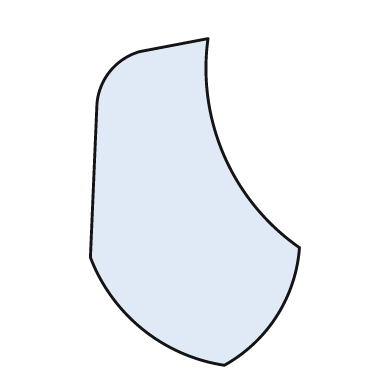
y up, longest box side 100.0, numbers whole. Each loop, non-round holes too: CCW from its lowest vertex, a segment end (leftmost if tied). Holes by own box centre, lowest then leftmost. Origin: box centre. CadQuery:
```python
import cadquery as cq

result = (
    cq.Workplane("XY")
    .moveTo(9.0, -50.0)
    .threePointArc((25.0, -35.0), (32.0, -14.0))
    .threePointArc((9.0, 14.0), (4.0, 50.0))
    .lineTo(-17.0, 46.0)
    .threePointArc((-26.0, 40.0), (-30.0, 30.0))
    .lineTo(-32.0, -17.0)
    .threePointArc((-16.0, -39.0), (9.0, -50.0))
    .close()
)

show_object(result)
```